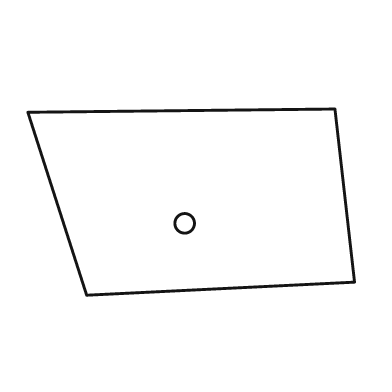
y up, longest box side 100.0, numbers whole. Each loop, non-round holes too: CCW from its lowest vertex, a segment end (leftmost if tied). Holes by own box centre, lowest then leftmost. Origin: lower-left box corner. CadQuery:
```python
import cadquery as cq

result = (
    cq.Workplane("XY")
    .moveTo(18.0, 0.0)
    .lineTo(100.0, 4.0)
    .lineTo(94.0, 57.0)
    .lineTo(0.0, 56.0)
    .close()
    .moveTo(48.0, 22.0)
    .circle(3.0)
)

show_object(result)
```